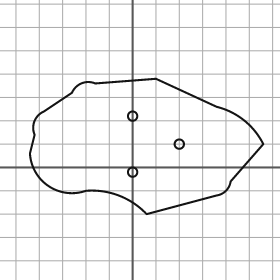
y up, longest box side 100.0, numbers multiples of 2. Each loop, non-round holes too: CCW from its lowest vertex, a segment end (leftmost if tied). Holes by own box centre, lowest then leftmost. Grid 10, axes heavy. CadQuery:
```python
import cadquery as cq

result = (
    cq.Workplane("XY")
    .moveTo(6.0, -20.0)
    .lineTo(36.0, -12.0)
    .threePointArc((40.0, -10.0), (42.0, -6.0))
    .lineTo(56.0, 10.0)
    .threePointArc((48.0, 20.0), (36.0, 26.0))
    .lineTo(10.0, 38.0)
    .lineTo(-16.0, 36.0)
    .threePointArc((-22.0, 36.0), (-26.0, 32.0))
    .lineTo(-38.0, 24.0)
    .threePointArc((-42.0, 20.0), (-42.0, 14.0))
    .lineTo(-44.0, 6.0)
    .threePointArc((-36.0, -8.0), (-20.0, -10.0))
    .threePointArc((-6.0, -12.0), (6.0, -20.0))
    .close()
    .moveTo(0.0, -2.0)
    .circle(2.0)
    .moveTo(20.0, 10.0)
    .circle(2.0)
    .moveTo(0.0, 22.0)
    .circle(2.0)
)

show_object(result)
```